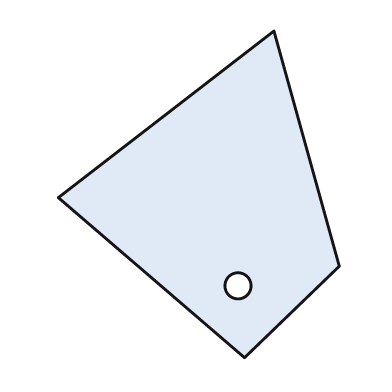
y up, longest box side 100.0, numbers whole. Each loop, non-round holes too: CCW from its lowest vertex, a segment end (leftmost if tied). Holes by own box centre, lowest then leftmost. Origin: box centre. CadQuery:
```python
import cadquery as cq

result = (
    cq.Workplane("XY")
    .moveTo(14.0, -50.0)
    .lineTo(43.0, -22.0)
    .lineTo(23.0, 50.0)
    .lineTo(-43.0, -1.0)
    .close()
    .moveTo(12.0, -28.0)
    .circle(4.0)
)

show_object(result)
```